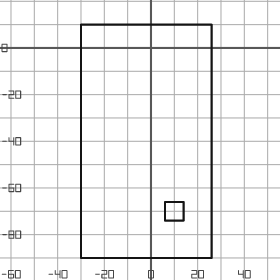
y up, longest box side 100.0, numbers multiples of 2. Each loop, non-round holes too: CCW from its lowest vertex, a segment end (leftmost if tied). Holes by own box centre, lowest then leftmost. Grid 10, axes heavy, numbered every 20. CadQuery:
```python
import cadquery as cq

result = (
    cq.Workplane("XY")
    .moveTo(-30.0, -90.0)
    .lineTo(26.0, -90.0)
    .lineTo(26.0, 10.0)
    .lineTo(-30.0, 10.0)
    .close()
    .moveTo(6.0, -74.0)
    .lineTo(14.0, -74.0)
    .lineTo(14.0, -66.0)
    .lineTo(6.0, -66.0)
    .close()
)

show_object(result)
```